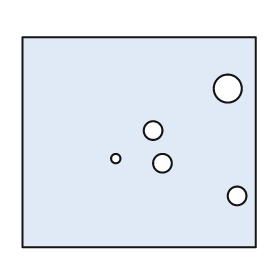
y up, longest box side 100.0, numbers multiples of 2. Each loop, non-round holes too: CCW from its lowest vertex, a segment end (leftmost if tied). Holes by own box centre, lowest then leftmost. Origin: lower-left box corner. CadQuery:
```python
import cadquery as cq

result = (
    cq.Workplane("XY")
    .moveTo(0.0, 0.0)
    .lineTo(100.0, 0.0)
    .lineTo(100.0, 90.0)
    .lineTo(0.0, 90.0)
    .close()
    .moveTo(92.0, 22.0)
    .circle(4.0)
    .moveTo(60.0, 36.0)
    .circle(4.0)
    .moveTo(40.0, 38.0)
    .circle(2.0)
    .moveTo(56.0, 50.0)
    .circle(4.0)
    .moveTo(88.0, 68.0)
    .circle(6.0)
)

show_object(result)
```